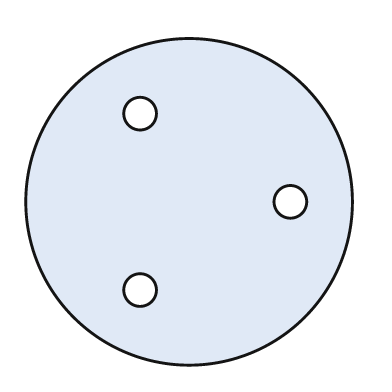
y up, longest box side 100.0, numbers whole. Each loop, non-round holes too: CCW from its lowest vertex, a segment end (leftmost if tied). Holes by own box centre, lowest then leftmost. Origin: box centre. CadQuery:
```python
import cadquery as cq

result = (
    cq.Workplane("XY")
    .moveTo(0.0, 0.0)
    .circle(50.0)
    .moveTo(-15.0, -27.0)
    .circle(5.0)
    .moveTo(31.0, 0.0)
    .circle(5.0)
    .moveTo(-15.0, 27.0)
    .circle(5.0)
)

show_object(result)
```